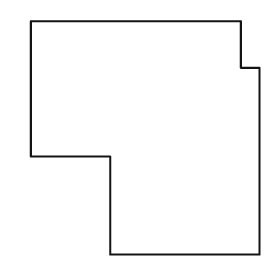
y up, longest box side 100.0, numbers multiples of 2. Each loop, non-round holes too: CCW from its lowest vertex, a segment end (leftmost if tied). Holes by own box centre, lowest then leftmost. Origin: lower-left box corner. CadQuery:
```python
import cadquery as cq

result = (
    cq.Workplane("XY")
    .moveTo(34.0, 0.0)
    .lineTo(98.0, 0.0)
    .lineTo(98.0, 80.0)
    .lineTo(90.0, 80.0)
    .lineTo(90.0, 100.0)
    .lineTo(0.0, 100.0)
    .lineTo(0.0, 42.0)
    .lineTo(34.0, 42.0)
    .close()
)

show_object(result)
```